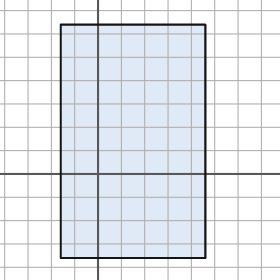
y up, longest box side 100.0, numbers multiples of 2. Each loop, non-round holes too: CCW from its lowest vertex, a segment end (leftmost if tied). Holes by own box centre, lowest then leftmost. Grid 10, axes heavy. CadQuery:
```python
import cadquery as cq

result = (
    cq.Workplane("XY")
    .moveTo(-16.0, -36.0)
    .lineTo(46.0, -36.0)
    .lineTo(46.0, 64.0)
    .lineTo(-16.0, 64.0)
    .close()
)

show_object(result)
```